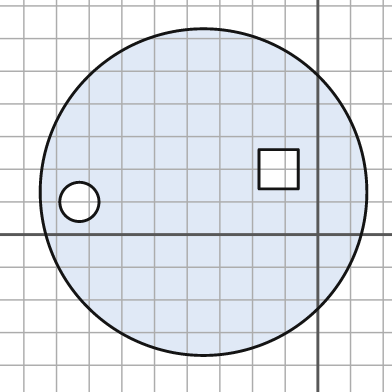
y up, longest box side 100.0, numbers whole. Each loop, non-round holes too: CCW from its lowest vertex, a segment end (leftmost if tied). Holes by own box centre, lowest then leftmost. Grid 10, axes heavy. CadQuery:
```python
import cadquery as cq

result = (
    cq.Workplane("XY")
    .moveTo(-35.0, 13.0)
    .circle(50.0)
    .moveTo(-73.0, 10.0)
    .circle(6.0)
    .moveTo(-18.0, 14.0)
    .lineTo(-6.0, 14.0)
    .lineTo(-6.0, 26.0)
    .lineTo(-18.0, 26.0)
    .close()
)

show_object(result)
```